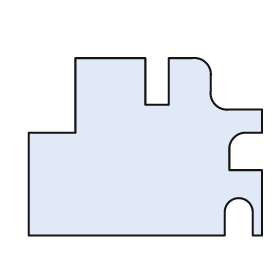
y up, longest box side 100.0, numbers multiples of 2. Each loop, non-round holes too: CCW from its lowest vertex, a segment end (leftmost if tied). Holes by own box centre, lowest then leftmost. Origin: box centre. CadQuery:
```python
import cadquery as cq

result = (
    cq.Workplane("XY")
    .moveTo(-50.0, -38.0)
    .lineTo(34.0, -38.0)
    .lineTo(34.0, -28.0)
    .threePointArc((40.0, -22.0), (46.0, -28.0))
    .lineTo(46.0, -38.0)
    .lineTo(50.0, -38.0)
    .lineTo(50.0, -10.0)
    .lineTo(36.0, -10.0)
    .lineTo(36.0, 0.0)
    .threePointArc((38.0, 4.0), (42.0, 6.0))
    .lineTo(50.0, 6.0)
    .lineTo(50.0, 16.0)
    .lineTo(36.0, 16.0)
    .threePointArc((30.0, 18.0), (28.0, 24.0))
    .lineTo(28.0, 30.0)
    .threePointArc((26.0, 36.0), (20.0, 38.0))
    .lineTo(10.0, 38.0)
    .lineTo(10.0, 18.0)
    .lineTo(0.0, 18.0)
    .lineTo(0.0, 38.0)
    .lineTo(-30.0, 38.0)
    .lineTo(-30.0, 6.0)
    .lineTo(-50.0, 6.0)
    .close()
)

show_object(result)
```